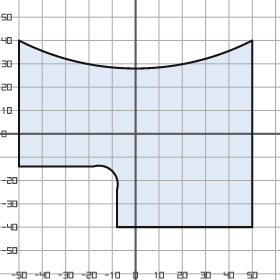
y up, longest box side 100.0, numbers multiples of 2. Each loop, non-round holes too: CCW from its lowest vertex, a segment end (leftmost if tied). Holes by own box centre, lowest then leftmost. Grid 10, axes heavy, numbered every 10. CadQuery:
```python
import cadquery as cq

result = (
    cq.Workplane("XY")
    .moveTo(-8.0, -40.0)
    .lineTo(50.0, -40.0)
    .lineTo(50.0, 40.0)
    .threePointArc((0.0, 28.0), (-50.0, 40.0))
    .lineTo(-50.0, -14.0)
    .lineTo(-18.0, -14.0)
    .threePointArc((-10.0, -16.0), (-8.0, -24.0))
    .close()
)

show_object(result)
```